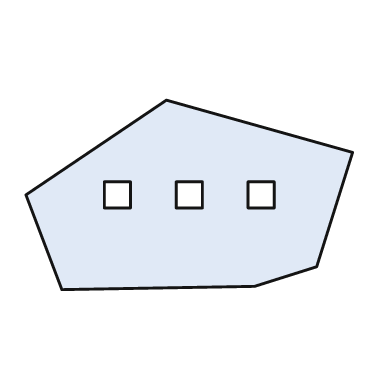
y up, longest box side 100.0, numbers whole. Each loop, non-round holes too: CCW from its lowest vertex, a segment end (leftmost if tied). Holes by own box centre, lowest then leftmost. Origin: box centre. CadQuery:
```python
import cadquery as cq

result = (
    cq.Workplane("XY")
    .moveTo(-39.0, -29.0)
    .lineTo(20.0, -28.0)
    .lineTo(39.0, -22.0)
    .lineTo(50.0, 13.0)
    .lineTo(-7.0, 29.0)
    .lineTo(-50.0, 0.0)
    .close()
    .moveTo(-26.0, -4.0)
    .lineTo(-18.0, -4.0)
    .lineTo(-18.0, 4.0)
    .lineTo(-26.0, 4.0)
    .close()
    .moveTo(-4.0, -4.0)
    .lineTo(4.0, -4.0)
    .lineTo(4.0, 4.0)
    .lineTo(-4.0, 4.0)
    .close()
    .moveTo(18.0, -4.0)
    .lineTo(26.0, -4.0)
    .lineTo(26.0, 4.0)
    .lineTo(18.0, 4.0)
    .close()
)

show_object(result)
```